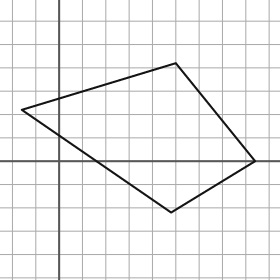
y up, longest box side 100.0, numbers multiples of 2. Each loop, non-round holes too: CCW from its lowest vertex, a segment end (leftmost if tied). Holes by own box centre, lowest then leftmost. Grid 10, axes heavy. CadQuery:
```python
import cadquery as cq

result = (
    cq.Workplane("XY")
    .moveTo(48.0, -22.0)
    .lineTo(84.0, 0.0)
    .lineTo(50.0, 42.0)
    .lineTo(-16.0, 22.0)
    .close()
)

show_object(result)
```